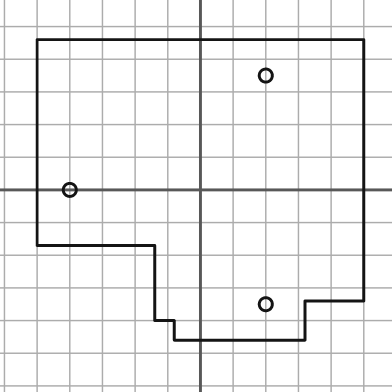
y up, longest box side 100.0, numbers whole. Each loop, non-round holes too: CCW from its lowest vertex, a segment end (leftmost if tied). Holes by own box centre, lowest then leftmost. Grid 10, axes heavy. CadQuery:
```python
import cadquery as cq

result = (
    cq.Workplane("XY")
    .moveTo(-8.0, -46.0)
    .lineTo(32.0, -46.0)
    .lineTo(32.0, -34.0)
    .lineTo(50.0, -34.0)
    .lineTo(50.0, 46.0)
    .lineTo(-50.0, 46.0)
    .lineTo(-50.0, -17.0)
    .lineTo(-14.0, -17.0)
    .lineTo(-14.0, -40.0)
    .lineTo(-8.0, -40.0)
    .close()
    .moveTo(20.0, -35.0)
    .circle(2.0)
    .moveTo(-40.0, 0.0)
    .circle(2.0)
    .moveTo(20.0, 35.0)
    .circle(2.0)
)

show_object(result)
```